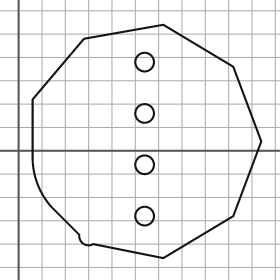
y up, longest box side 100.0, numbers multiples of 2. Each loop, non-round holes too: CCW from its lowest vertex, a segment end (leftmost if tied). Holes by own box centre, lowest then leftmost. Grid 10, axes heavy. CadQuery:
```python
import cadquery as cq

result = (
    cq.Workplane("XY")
    .moveTo(62.0, -46.0)
    .lineTo(92.0, -28.0)
    .lineTo(104.0, 4.0)
    .lineTo(92.0, 36.0)
    .lineTo(62.0, 54.0)
    .lineTo(28.0, 48.0)
    .lineTo(6.0, 22.0)
    .lineTo(6.0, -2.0)
    .threePointArc((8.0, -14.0), (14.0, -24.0))
    .lineTo(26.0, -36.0)
    .threePointArc((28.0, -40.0), (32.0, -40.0))
    .close()
    .moveTo(54.0, -28.0)
    .circle(4.0)
    .moveTo(54.0, -6.0)
    .circle(4.0)
    .moveTo(54.0, 16.0)
    .circle(4.0)
    .moveTo(54.0, 38.0)
    .circle(4.0)
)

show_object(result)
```